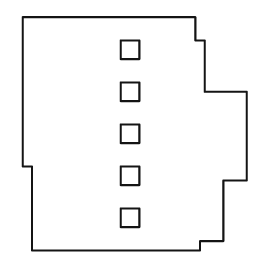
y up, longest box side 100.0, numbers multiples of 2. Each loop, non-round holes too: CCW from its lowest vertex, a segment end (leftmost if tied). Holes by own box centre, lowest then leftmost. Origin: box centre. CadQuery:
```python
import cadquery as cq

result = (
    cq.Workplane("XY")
    .moveTo(-44.0, -50.0)
    .lineTo(28.0, -50.0)
    .lineTo(28.0, -46.0)
    .lineTo(38.0, -46.0)
    .lineTo(38.0, -20.0)
    .lineTo(48.0, -20.0)
    .lineTo(48.0, 18.0)
    .lineTo(30.0, 18.0)
    .lineTo(30.0, 40.0)
    .lineTo(26.0, 40.0)
    .lineTo(26.0, 50.0)
    .lineTo(-48.0, 50.0)
    .lineTo(-48.0, -14.0)
    .lineTo(-44.0, -14.0)
    .close()
    .moveTo(-6.0, -40.0)
    .lineTo(2.0, -40.0)
    .lineTo(2.0, -32.0)
    .lineTo(-6.0, -32.0)
    .close()
    .moveTo(-6.0, -22.0)
    .lineTo(2.0, -22.0)
    .lineTo(2.0, -14.0)
    .lineTo(-6.0, -14.0)
    .close()
    .moveTo(-6.0, -4.0)
    .lineTo(2.0, -4.0)
    .lineTo(2.0, 4.0)
    .lineTo(-6.0, 4.0)
    .close()
    .moveTo(-6.0, 14.0)
    .lineTo(2.0, 14.0)
    .lineTo(2.0, 22.0)
    .lineTo(-6.0, 22.0)
    .close()
    .moveTo(-6.0, 32.0)
    .lineTo(2.0, 32.0)
    .lineTo(2.0, 40.0)
    .lineTo(-6.0, 40.0)
    .close()
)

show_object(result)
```